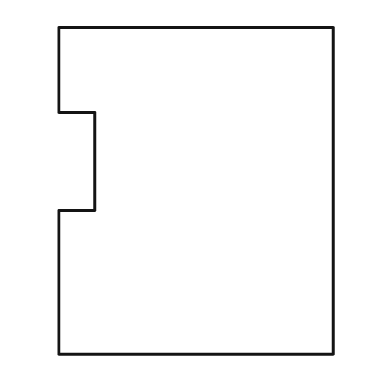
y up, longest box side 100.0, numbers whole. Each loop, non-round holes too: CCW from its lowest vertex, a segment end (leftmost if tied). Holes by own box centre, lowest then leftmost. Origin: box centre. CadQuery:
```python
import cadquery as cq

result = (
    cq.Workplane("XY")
    .moveTo(-42.0, -50.0)
    .lineTo(42.0, -50.0)
    .lineTo(42.0, 50.0)
    .lineTo(-42.0, 50.0)
    .lineTo(-42.0, 24.0)
    .lineTo(-31.0, 24.0)
    .lineTo(-31.0, -6.0)
    .lineTo(-42.0, -6.0)
    .close()
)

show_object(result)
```